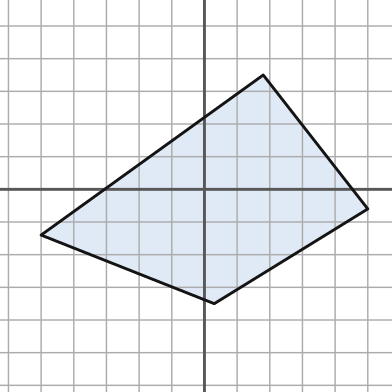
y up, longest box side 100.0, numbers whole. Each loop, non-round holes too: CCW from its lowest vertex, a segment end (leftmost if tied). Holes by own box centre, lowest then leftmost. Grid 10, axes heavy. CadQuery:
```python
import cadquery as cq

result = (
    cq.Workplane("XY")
    .moveTo(3.0, -35.0)
    .lineTo(50.0, -6.0)
    .lineTo(18.0, 35.0)
    .lineTo(-50.0, -14.0)
    .close()
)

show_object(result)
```